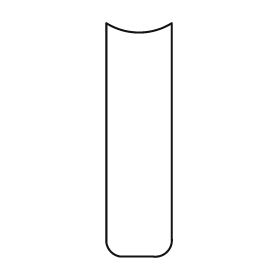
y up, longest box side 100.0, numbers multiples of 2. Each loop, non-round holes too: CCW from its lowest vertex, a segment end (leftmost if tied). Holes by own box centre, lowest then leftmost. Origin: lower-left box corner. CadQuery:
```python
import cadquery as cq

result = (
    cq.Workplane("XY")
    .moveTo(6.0, 0.0)
    .lineTo(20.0, 0.0)
    .threePointArc((26.0, 2.0), (28.0, 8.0))
    .lineTo(28.0, 100.0)
    .threePointArc((14.0, 96.0), (0.0, 100.0))
    .lineTo(0.0, 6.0)
    .threePointArc((2.0, 2.0), (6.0, 0.0))
    .close()
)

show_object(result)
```